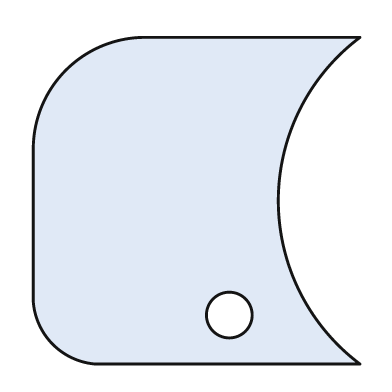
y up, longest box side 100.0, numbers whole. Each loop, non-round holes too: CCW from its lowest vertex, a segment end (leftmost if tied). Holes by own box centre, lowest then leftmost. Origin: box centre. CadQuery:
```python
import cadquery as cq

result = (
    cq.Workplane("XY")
    .moveTo(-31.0, -50.0)
    .lineTo(50.0, -50.0)
    .threePointArc((25.0, 0.0), (50.0, 50.0))
    .lineTo(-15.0, 50.0)
    .threePointArc((-40.0, 40.0), (-50.0, 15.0))
    .lineTo(-50.0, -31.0)
    .threePointArc((-44.0, -44.0), (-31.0, -50.0))
    .close()
    .moveTo(10.0, -35.0)
    .circle(7.0)
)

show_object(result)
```